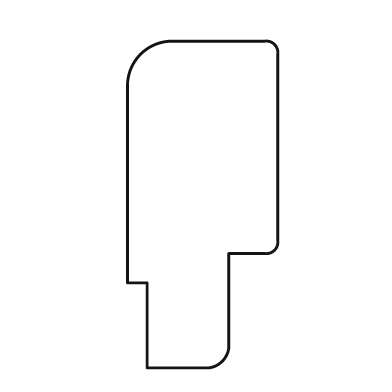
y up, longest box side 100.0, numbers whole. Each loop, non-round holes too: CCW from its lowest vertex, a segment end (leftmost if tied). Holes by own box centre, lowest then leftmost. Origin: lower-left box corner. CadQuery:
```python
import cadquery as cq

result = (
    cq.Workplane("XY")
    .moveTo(6.0, 0.0)
    .lineTo(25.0, 0.0)
    .threePointArc((29.0, 2.0), (31.0, 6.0))
    .lineTo(31.0, 35.0)
    .lineTo(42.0, 35.0)
    .threePointArc((45.0, 36.0), (46.0, 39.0))
    .lineTo(46.0, 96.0)
    .threePointArc((45.0, 99.0), (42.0, 100.0))
    .lineTo(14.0, 100.0)
    .threePointArc((4.0, 96.0), (0.0, 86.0))
    .lineTo(0.0, 26.0)
    .lineTo(6.0, 26.0)
    .close()
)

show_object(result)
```